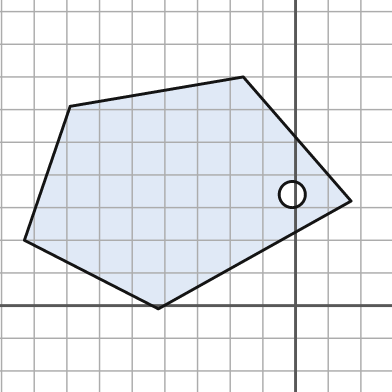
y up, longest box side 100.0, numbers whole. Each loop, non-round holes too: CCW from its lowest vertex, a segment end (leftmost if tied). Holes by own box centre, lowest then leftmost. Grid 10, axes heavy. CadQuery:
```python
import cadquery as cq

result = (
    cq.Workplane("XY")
    .moveTo(-42.0, -1.0)
    .lineTo(17.0, 32.0)
    .lineTo(-16.0, 70.0)
    .lineTo(-69.0, 61.0)
    .lineTo(-83.0, 20.0)
    .close()
    .moveTo(-1.0, 34.0)
    .circle(4.0)
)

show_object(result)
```